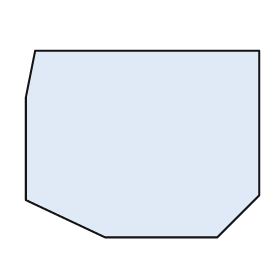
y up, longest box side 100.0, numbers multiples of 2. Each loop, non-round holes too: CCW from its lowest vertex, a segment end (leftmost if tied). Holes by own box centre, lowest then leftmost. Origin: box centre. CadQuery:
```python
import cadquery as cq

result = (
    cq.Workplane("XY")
    .moveTo(-16.0, -40.0)
    .lineTo(32.0, -40.0)
    .lineTo(50.0, -22.0)
    .lineTo(50.0, 40.0)
    .lineTo(-46.0, 40.0)
    .lineTo(-50.0, 20.0)
    .lineTo(-50.0, -24.0)
    .close()
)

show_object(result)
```